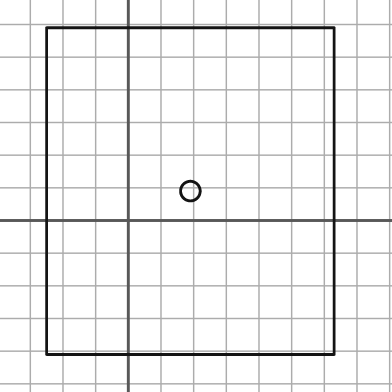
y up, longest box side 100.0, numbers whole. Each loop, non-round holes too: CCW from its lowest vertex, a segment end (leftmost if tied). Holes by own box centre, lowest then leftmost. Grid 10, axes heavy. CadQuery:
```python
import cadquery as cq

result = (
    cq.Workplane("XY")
    .moveTo(-25.0, -41.0)
    .lineTo(63.0, -41.0)
    .lineTo(63.0, 59.0)
    .lineTo(-25.0, 59.0)
    .close()
    .moveTo(19.0, 9.0)
    .circle(3.0)
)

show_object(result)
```